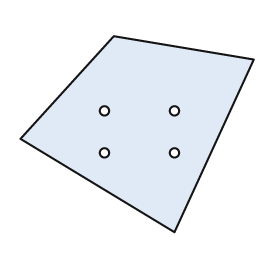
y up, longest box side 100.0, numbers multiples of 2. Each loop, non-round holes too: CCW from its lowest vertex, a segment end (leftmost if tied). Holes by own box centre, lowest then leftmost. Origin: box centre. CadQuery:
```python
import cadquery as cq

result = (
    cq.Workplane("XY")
    .moveTo(16.0, -42.0)
    .lineTo(50.0, 32.0)
    .lineTo(-10.0, 42.0)
    .lineTo(-50.0, -2.0)
    .close()
    .moveTo(-14.0, -8.0)
    .circle(2.0)
    .moveTo(16.0, -8.0)
    .circle(2.0)
    .moveTo(-14.0, 10.0)
    .circle(2.0)
    .moveTo(16.0, 10.0)
    .circle(2.0)
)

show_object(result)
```